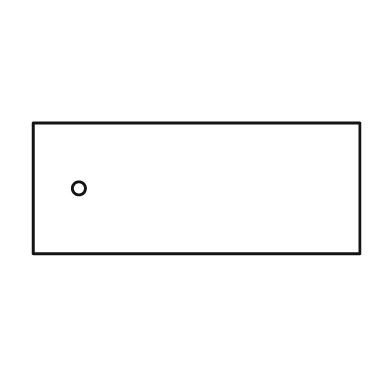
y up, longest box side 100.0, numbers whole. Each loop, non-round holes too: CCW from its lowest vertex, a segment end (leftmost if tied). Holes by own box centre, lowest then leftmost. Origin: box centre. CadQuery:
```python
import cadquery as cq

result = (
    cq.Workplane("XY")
    .moveTo(-50.0, -20.0)
    .lineTo(50.0, -20.0)
    .lineTo(50.0, 20.0)
    .lineTo(-50.0, 20.0)
    .close()
    .moveTo(-36.0, 0.0)
    .circle(2.0)
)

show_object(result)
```